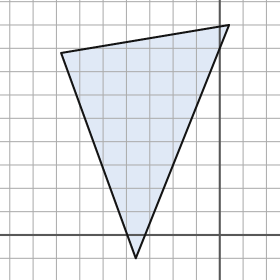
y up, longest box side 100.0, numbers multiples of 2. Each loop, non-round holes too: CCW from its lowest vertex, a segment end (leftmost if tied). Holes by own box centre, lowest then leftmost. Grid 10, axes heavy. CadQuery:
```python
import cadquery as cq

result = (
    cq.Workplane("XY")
    .moveTo(-36.0, -10.0)
    .lineTo(4.0, 90.0)
    .lineTo(-68.0, 78.0)
    .close()
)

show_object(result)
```